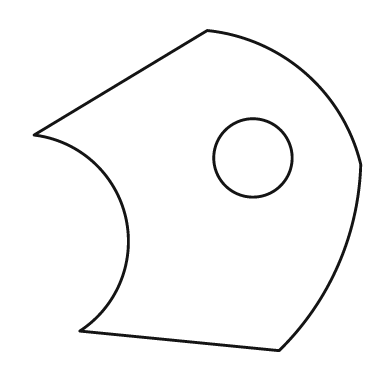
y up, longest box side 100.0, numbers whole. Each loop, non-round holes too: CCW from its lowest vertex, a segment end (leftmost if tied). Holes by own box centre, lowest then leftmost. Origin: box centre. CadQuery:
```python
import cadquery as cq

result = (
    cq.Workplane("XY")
    .moveTo(25.0, -49.0)
    .threePointArc((43.0, -23.0), (50.0, 8.0))
    .threePointArc((33.0, 36.0), (3.0, 49.0))
    .lineTo(-50.0, 17.0)
    .threePointArc((-22.0, -8.0), (-36.0, -43.0))
    .close()
    .moveTo(17.0, 10.0)
    .circle(12.0)
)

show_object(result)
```